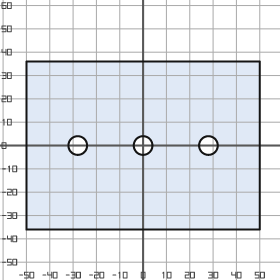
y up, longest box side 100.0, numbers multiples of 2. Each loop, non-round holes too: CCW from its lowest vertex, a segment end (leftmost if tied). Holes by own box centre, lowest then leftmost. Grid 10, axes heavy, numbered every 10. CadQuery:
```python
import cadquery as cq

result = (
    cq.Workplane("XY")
    .moveTo(-50.0, -36.0)
    .lineTo(50.0, -36.0)
    .lineTo(50.0, 36.0)
    .lineTo(-50.0, 36.0)
    .close()
    .moveTo(-28.0, 0.0)
    .circle(4.0)
    .moveTo(0.0, 0.0)
    .circle(4.0)
    .moveTo(28.0, 0.0)
    .circle(4.0)
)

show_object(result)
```